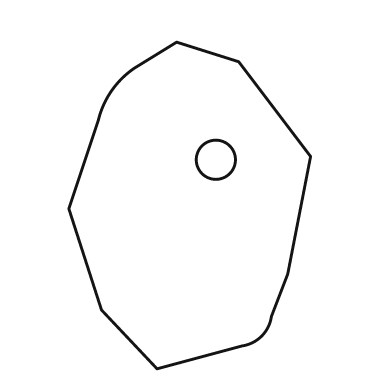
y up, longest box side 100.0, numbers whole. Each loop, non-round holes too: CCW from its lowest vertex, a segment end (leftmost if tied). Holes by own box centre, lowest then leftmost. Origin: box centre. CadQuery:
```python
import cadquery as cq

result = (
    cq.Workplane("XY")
    .moveTo(-10.0, -50.0)
    .lineTo(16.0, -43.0)
    .threePointArc((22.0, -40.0), (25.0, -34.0))
    .lineTo(30.0, -21.0)
    .lineTo(37.0, 15.0)
    .lineTo(15.0, 44.0)
    .lineTo(-4.0, 50.0)
    .lineTo(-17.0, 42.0)
    .threePointArc((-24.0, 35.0), (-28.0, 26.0))
    .lineTo(-37.0, -1.0)
    .lineTo(-27.0, -32.0)
    .close()
    .moveTo(8.0, 14.0)
    .circle(6.0)
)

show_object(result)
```